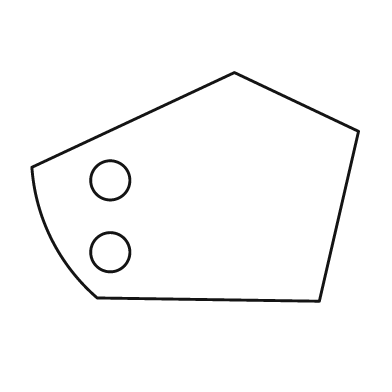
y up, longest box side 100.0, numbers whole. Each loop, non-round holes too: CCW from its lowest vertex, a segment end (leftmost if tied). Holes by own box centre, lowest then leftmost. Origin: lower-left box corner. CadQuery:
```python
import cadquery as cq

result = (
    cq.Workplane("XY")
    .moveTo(88.0, 0.0)
    .lineTo(100.0, 52.0)
    .lineTo(62.0, 70.0)
    .lineTo(0.0, 41.0)
    .threePointArc((6.0, 19.0), (20.0, 1.0))
    .close()
    .moveTo(24.0, 15.0)
    .circle(6.0)
    .moveTo(24.0, 37.0)
    .circle(6.0)
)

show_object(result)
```